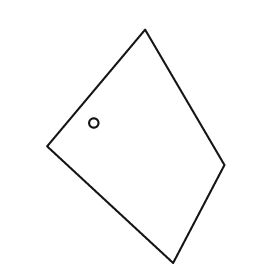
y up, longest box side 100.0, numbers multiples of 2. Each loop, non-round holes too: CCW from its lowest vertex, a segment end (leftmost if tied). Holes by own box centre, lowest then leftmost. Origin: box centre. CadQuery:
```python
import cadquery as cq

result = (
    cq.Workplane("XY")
    .moveTo(16.0, -50.0)
    .lineTo(38.0, -8.0)
    .lineTo(4.0, 50.0)
    .lineTo(-38.0, 0.0)
    .close()
    .moveTo(-18.0, 10.0)
    .circle(2.0)
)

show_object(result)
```